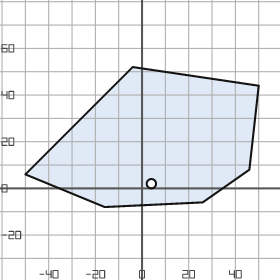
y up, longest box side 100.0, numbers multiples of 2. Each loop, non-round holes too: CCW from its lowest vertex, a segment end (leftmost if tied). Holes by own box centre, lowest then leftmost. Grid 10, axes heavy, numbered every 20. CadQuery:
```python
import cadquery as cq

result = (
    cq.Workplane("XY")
    .moveTo(-16.0, -8.0)
    .lineTo(26.0, -6.0)
    .lineTo(46.0, 8.0)
    .lineTo(50.0, 44.0)
    .lineTo(-4.0, 52.0)
    .lineTo(-50.0, 6.0)
    .close()
    .moveTo(4.0, 2.0)
    .circle(2.0)
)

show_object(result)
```